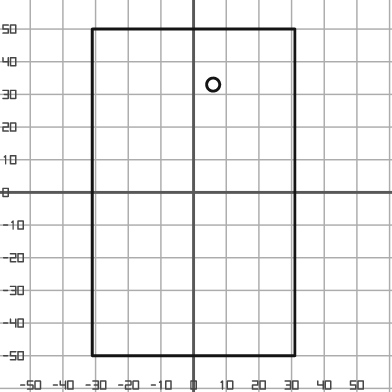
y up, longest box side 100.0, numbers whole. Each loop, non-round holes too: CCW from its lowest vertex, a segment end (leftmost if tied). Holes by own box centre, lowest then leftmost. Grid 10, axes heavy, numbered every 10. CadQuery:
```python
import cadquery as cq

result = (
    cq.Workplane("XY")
    .moveTo(-31.0, -50.0)
    .lineTo(31.0, -50.0)
    .lineTo(31.0, 50.0)
    .lineTo(-31.0, 50.0)
    .close()
    .moveTo(6.0, 33.0)
    .circle(2.0)
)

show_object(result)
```